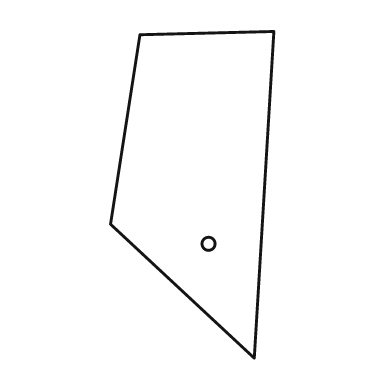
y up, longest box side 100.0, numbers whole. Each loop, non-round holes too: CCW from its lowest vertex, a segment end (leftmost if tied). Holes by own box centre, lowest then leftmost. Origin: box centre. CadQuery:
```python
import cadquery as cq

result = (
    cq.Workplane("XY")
    .moveTo(19.0, -50.0)
    .lineTo(25.0, 50.0)
    .lineTo(-16.0, 49.0)
    .lineTo(-25.0, -9.0)
    .close()
    .moveTo(5.0, -15.0)
    .circle(2.0)
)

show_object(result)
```